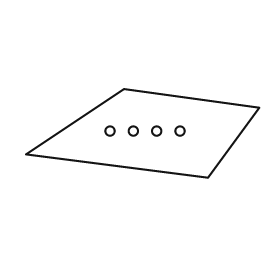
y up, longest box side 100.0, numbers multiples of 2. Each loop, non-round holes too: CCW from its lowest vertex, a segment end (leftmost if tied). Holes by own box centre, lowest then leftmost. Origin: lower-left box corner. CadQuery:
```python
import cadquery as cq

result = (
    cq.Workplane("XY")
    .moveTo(78.0, 0.0)
    .lineTo(100.0, 30.0)
    .lineTo(42.0, 38.0)
    .lineTo(0.0, 10.0)
    .close()
    .moveTo(36.0, 20.0)
    .circle(2.0)
    .moveTo(46.0, 20.0)
    .circle(2.0)
    .moveTo(56.0, 20.0)
    .circle(2.0)
    .moveTo(66.0, 20.0)
    .circle(2.0)
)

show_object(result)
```